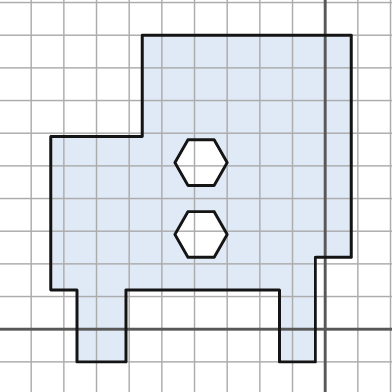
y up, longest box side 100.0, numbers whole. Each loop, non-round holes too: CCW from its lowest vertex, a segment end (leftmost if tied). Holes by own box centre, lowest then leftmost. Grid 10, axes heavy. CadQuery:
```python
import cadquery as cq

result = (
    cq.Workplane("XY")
    .moveTo(-76.0, -10.0)
    .lineTo(-61.0, -10.0)
    .lineTo(-61.0, 12.0)
    .lineTo(-14.0, 12.0)
    .lineTo(-14.0, -10.0)
    .lineTo(-3.0, -10.0)
    .lineTo(-3.0, 22.0)
    .lineTo(8.0, 22.0)
    .lineTo(8.0, 90.0)
    .lineTo(-56.0, 90.0)
    .lineTo(-56.0, 59.0)
    .lineTo(-84.0, 59.0)
    .lineTo(-84.0, 12.0)
    .lineTo(-76.0, 12.0)
    .close()
    .moveTo(-42.0, 22.0)
    .lineTo(-34.0, 22.0)
    .lineTo(-30.0, 29.0)
    .lineTo(-34.0, 36.0)
    .lineTo(-42.0, 36.0)
    .lineTo(-46.0, 29.0)
    .close()
    .moveTo(-42.0, 44.0)
    .lineTo(-34.0, 44.0)
    .lineTo(-30.0, 51.0)
    .lineTo(-34.0, 58.0)
    .lineTo(-42.0, 58.0)
    .lineTo(-46.0, 51.0)
    .close()
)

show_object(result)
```